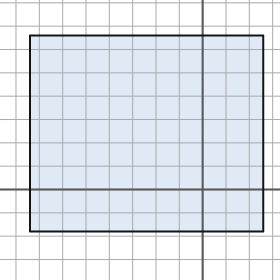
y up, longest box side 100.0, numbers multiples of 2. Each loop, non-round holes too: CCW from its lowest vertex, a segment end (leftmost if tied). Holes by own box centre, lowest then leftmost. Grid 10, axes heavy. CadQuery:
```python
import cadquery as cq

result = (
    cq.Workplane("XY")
    .moveTo(-74.0, -18.0)
    .lineTo(26.0, -18.0)
    .lineTo(26.0, 66.0)
    .lineTo(-74.0, 66.0)
    .close()
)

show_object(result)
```